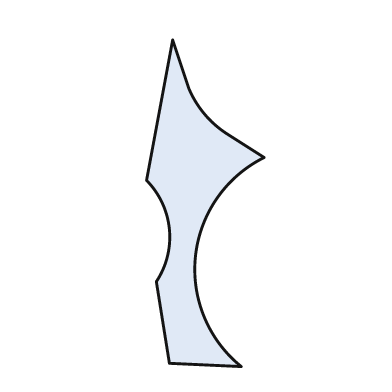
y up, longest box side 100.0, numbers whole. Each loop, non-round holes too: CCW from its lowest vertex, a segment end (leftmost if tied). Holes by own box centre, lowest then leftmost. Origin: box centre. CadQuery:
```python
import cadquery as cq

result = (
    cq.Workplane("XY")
    .moveTo(11.0, -50.0)
    .threePointArc((-3.0, -16.0), (18.0, 14.0))
    .lineTo(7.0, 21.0)
    .threePointArc((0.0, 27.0), (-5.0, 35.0))
    .lineTo(-10.0, 50.0)
    .lineTo(-18.0, 7.0)
    .threePointArc((-11.0, -8.0), (-15.0, -24.0))
    .lineTo(-11.0, -49.0)
    .close()
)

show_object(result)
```